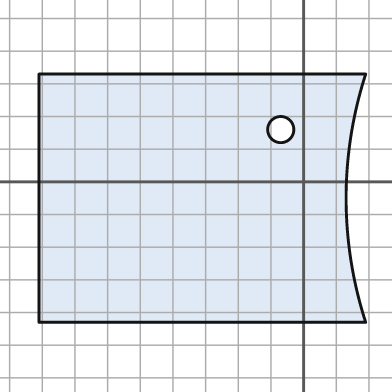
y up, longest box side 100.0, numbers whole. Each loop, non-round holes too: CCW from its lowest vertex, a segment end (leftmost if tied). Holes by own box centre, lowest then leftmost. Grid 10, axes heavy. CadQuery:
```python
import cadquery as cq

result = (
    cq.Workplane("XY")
    .moveTo(-81.0, -43.0)
    .lineTo(19.0, -43.0)
    .threePointArc((13.0, -5.0), (19.0, 33.0))
    .lineTo(-81.0, 33.0)
    .close()
    .moveTo(-7.0, 16.0)
    .circle(4.0)
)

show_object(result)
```